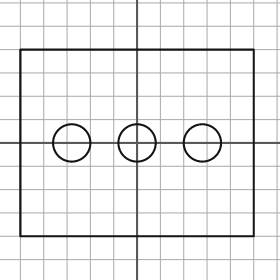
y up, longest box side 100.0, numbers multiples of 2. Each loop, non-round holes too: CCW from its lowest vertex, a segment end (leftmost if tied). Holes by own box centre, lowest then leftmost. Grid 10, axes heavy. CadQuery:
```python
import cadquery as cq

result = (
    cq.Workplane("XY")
    .moveTo(-50.0, -40.0)
    .lineTo(50.0, -40.0)
    .lineTo(50.0, 40.0)
    .lineTo(-50.0, 40.0)
    .close()
    .moveTo(-28.0, 0.0)
    .circle(8.0)
    .moveTo(0.0, 0.0)
    .circle(8.0)
    .moveTo(28.0, 0.0)
    .circle(8.0)
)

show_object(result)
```